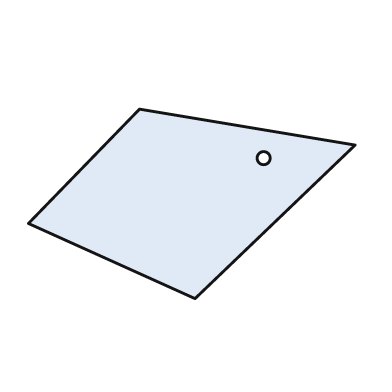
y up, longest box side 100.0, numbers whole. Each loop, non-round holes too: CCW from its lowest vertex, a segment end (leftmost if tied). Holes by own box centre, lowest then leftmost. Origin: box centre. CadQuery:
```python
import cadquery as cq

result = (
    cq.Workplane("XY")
    .moveTo(1.0, -29.0)
    .lineTo(50.0, 18.0)
    .lineTo(-16.0, 29.0)
    .lineTo(-50.0, -6.0)
    .close()
    .moveTo(22.0, 14.0)
    .circle(2.0)
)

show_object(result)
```